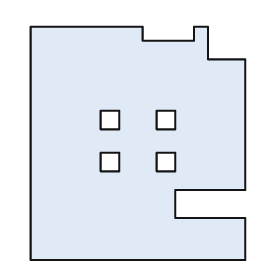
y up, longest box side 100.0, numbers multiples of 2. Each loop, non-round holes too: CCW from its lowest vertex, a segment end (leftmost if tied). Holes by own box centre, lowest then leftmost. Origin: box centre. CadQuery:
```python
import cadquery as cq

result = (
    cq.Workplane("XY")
    .moveTo(-46.0, -50.0)
    .lineTo(46.0, -50.0)
    .lineTo(46.0, -32.0)
    .lineTo(16.0, -32.0)
    .lineTo(16.0, -20.0)
    .lineTo(46.0, -20.0)
    .lineTo(46.0, 36.0)
    .lineTo(30.0, 36.0)
    .lineTo(30.0, 50.0)
    .lineTo(24.0, 50.0)
    .lineTo(24.0, 44.0)
    .lineTo(2.0, 44.0)
    .lineTo(2.0, 50.0)
    .lineTo(-46.0, 50.0)
    .close()
    .moveTo(-16.0, -12.0)
    .lineTo(-8.0, -12.0)
    .lineTo(-8.0, -4.0)
    .lineTo(-16.0, -4.0)
    .close()
    .moveTo(8.0, -12.0)
    .lineTo(16.0, -12.0)
    .lineTo(16.0, -4.0)
    .lineTo(8.0, -4.0)
    .close()
    .moveTo(-16.0, 6.0)
    .lineTo(-8.0, 6.0)
    .lineTo(-8.0, 14.0)
    .lineTo(-16.0, 14.0)
    .close()
    .moveTo(8.0, 6.0)
    .lineTo(16.0, 6.0)
    .lineTo(16.0, 14.0)
    .lineTo(8.0, 14.0)
    .close()
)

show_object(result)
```